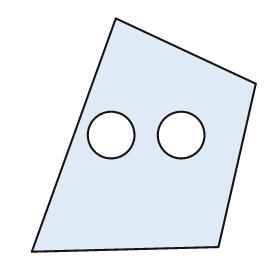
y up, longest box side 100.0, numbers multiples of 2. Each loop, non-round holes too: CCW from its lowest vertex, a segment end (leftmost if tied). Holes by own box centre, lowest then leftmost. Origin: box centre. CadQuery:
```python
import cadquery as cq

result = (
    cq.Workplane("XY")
    .moveTo(-48.0, -50.0)
    .lineTo(32.0, -48.0)
    .lineTo(48.0, 22.0)
    .lineTo(-12.0, 50.0)
    .close()
    .moveTo(-14.0, 0.0)
    .circle(10.0)
    .moveTo(16.0, 0.0)
    .circle(10.0)
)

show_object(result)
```